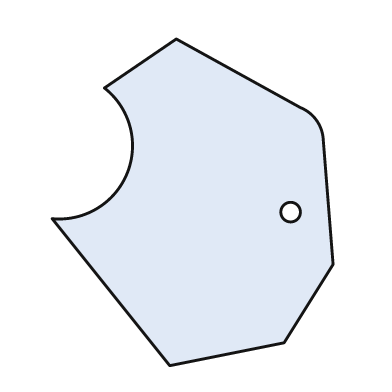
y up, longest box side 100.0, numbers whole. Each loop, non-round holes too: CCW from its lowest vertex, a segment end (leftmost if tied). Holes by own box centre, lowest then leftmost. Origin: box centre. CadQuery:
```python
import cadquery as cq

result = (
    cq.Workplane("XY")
    .moveTo(-7.0, -50.0)
    .lineTo(28.0, -43.0)
    .lineTo(43.0, -19.0)
    .lineTo(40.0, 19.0)
    .threePointArc((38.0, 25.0), (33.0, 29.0))
    .lineTo(-5.0, 50.0)
    .lineTo(-27.0, 35.0)
    .threePointArc((-20.0, 9.0), (-43.0, -5.0))
    .close()
    .moveTo(30.0, -3.0)
    .circle(3.0)
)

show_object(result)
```